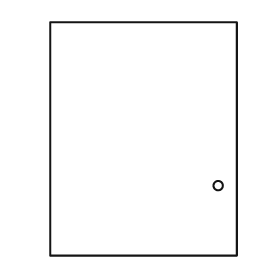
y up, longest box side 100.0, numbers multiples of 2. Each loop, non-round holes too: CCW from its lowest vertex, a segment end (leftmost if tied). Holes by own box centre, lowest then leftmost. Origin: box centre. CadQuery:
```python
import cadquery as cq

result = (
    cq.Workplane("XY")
    .moveTo(-40.0, -50.0)
    .lineTo(40.0, -50.0)
    .lineTo(40.0, 50.0)
    .lineTo(-40.0, 50.0)
    .close()
    .moveTo(32.0, -20.0)
    .circle(2.0)
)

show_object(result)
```